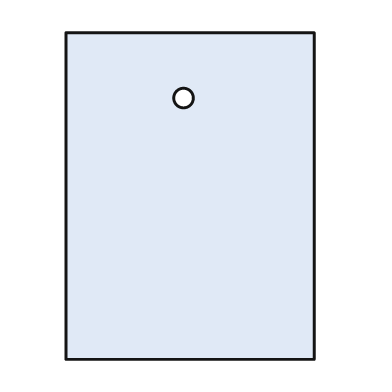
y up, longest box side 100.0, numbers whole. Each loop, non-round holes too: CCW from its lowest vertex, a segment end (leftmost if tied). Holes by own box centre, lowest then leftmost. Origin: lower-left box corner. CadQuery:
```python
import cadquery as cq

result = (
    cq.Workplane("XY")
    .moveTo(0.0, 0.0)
    .lineTo(76.0, 0.0)
    .lineTo(76.0, 100.0)
    .lineTo(0.0, 100.0)
    .close()
    .moveTo(36.0, 80.0)
    .circle(3.0)
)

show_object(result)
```